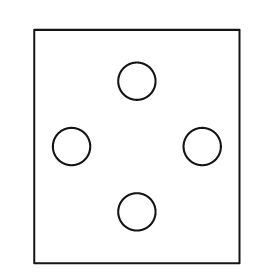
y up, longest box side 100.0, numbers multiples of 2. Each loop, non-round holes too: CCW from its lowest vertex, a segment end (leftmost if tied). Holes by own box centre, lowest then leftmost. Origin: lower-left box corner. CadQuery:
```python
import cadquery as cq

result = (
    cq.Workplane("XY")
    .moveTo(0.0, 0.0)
    .lineTo(88.0, 0.0)
    .lineTo(88.0, 100.0)
    .lineTo(0.0, 100.0)
    .close()
    .moveTo(44.0, 22.0)
    .circle(8.0)
    .moveTo(16.0, 50.0)
    .circle(8.0)
    .moveTo(72.0, 50.0)
    .circle(8.0)
    .moveTo(44.0, 78.0)
    .circle(8.0)
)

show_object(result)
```